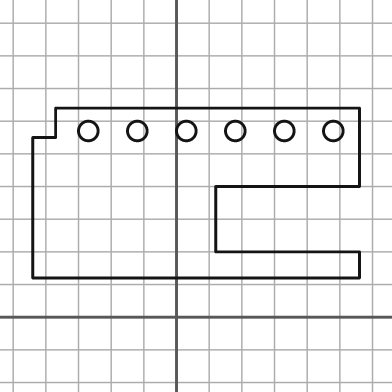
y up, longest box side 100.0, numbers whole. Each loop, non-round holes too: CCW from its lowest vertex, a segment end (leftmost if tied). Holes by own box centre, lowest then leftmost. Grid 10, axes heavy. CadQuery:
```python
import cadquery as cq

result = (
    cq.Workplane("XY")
    .moveTo(-44.0, 12.0)
    .lineTo(56.0, 12.0)
    .lineTo(56.0, 20.0)
    .lineTo(12.0, 20.0)
    .lineTo(12.0, 40.0)
    .lineTo(56.0, 40.0)
    .lineTo(56.0, 64.0)
    .lineTo(-37.0, 64.0)
    .lineTo(-37.0, 55.0)
    .lineTo(-44.0, 55.0)
    .close()
    .moveTo(-27.0, 57.0)
    .circle(3.0)
    .moveTo(-12.0, 57.0)
    .circle(3.0)
    .moveTo(3.0, 57.0)
    .circle(3.0)
    .moveTo(18.0, 57.0)
    .circle(3.0)
    .moveTo(33.0, 57.0)
    .circle(3.0)
    .moveTo(48.0, 57.0)
    .circle(3.0)
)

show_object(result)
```